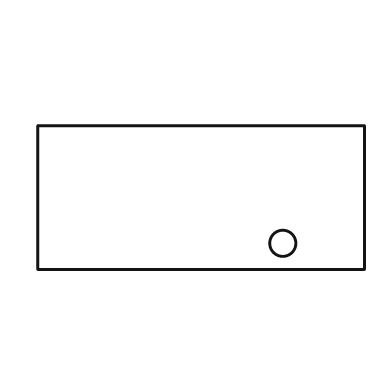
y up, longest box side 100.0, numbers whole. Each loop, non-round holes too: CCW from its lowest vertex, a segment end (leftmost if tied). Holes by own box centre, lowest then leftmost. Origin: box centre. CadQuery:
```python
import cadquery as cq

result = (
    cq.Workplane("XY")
    .moveTo(-50.0, -22.0)
    .lineTo(50.0, -22.0)
    .lineTo(50.0, 22.0)
    .lineTo(-50.0, 22.0)
    .close()
    .moveTo(25.0, -14.0)
    .circle(4.0)
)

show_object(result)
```